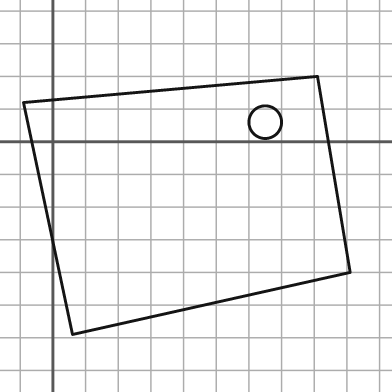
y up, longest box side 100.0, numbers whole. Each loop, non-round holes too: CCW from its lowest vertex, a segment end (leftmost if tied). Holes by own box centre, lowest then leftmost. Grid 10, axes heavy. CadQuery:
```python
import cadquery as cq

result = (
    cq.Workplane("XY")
    .moveTo(6.0, -59.0)
    .lineTo(91.0, -40.0)
    .lineTo(81.0, 20.0)
    .lineTo(-9.0, 12.0)
    .close()
    .moveTo(65.0, 6.0)
    .circle(5.0)
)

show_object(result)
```